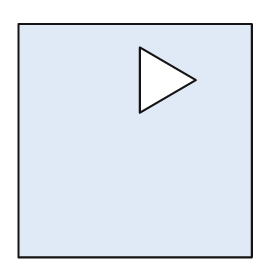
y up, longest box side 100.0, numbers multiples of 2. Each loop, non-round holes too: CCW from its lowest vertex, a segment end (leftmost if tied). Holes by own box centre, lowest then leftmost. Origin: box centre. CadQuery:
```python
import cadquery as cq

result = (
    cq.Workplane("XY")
    .moveTo(-50.0, -50.0)
    .lineTo(50.0, -50.0)
    .lineTo(50.0, 50.0)
    .lineTo(-50.0, 50.0)
    .close()
    .moveTo(2.0, 12.0)
    .lineTo(26.0, 26.0)
    .lineTo(2.0, 40.0)
    .close()
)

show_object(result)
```